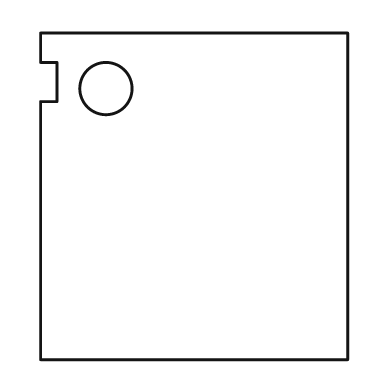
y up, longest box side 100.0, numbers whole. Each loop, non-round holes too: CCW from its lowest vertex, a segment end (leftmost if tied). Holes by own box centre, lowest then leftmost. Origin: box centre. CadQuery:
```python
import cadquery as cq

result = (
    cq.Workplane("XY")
    .moveTo(-47.0, -50.0)
    .lineTo(47.0, -50.0)
    .lineTo(47.0, 50.0)
    .lineTo(-47.0, 50.0)
    .lineTo(-47.0, 41.0)
    .lineTo(-42.0, 41.0)
    .lineTo(-42.0, 29.0)
    .lineTo(-47.0, 29.0)
    .close()
    .moveTo(-27.0, 33.0)
    .circle(8.0)
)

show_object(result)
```